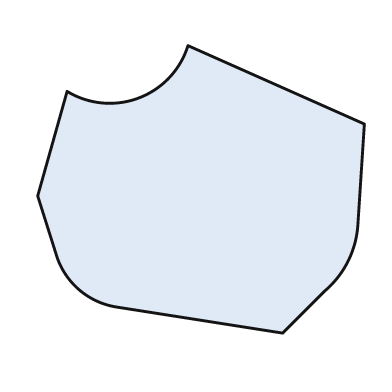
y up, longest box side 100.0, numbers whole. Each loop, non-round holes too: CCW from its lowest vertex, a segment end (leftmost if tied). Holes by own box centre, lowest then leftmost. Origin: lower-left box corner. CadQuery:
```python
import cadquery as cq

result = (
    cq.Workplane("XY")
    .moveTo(75.0, 0.0)
    .lineTo(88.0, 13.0)
    .threePointArc((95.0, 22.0), (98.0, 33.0))
    .lineTo(100.0, 64.0)
    .lineTo(46.0, 88.0)
    .threePointArc((31.0, 72.0), (9.0, 74.0))
    .lineTo(0.0, 42.0)
    .lineTo(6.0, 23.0)
    .threePointArc((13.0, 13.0), (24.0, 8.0))
    .close()
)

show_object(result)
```